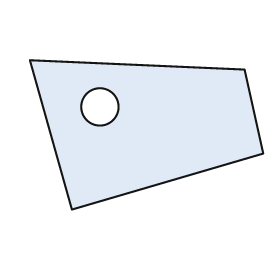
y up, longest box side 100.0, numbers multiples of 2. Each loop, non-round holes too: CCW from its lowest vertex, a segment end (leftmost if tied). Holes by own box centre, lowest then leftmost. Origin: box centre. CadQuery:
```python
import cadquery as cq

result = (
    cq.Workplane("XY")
    .moveTo(-32.0, -32.0)
    .lineTo(50.0, -8.0)
    .lineTo(42.0, 28.0)
    .lineTo(-50.0, 32.0)
    .close()
    .moveTo(-20.0, 12.0)
    .circle(8.0)
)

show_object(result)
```